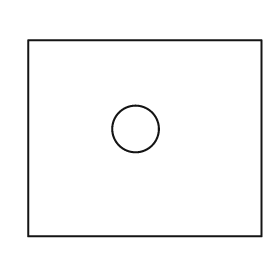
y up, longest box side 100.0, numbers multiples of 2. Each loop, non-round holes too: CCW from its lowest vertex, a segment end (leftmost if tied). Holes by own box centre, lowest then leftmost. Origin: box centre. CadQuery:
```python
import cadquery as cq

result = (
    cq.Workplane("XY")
    .moveTo(-50.0, -42.0)
    .lineTo(50.0, -42.0)
    .lineTo(50.0, 42.0)
    .lineTo(-50.0, 42.0)
    .close()
    .moveTo(-4.0, 4.0)
    .circle(10.0)
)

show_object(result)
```